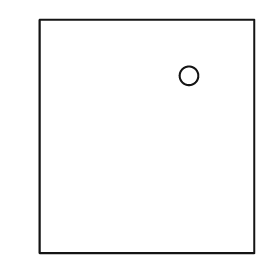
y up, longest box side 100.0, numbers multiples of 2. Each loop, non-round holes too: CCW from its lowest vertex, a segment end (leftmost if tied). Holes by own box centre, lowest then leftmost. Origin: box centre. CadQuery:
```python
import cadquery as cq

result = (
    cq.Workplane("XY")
    .moveTo(-46.0, -50.0)
    .lineTo(46.0, -50.0)
    .lineTo(46.0, 50.0)
    .lineTo(-46.0, 50.0)
    .close()
    .moveTo(18.0, 26.0)
    .circle(4.0)
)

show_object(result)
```